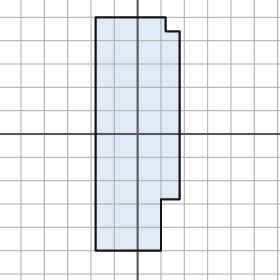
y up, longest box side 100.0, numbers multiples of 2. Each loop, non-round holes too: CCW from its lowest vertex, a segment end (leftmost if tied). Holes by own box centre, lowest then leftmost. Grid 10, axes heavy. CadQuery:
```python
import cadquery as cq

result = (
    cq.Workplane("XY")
    .moveTo(-18.0, -50.0)
    .lineTo(10.0, -50.0)
    .lineTo(10.0, -28.0)
    .lineTo(18.0, -28.0)
    .lineTo(18.0, 44.0)
    .lineTo(12.0, 44.0)
    .lineTo(12.0, 50.0)
    .lineTo(-18.0, 50.0)
    .close()
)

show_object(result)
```